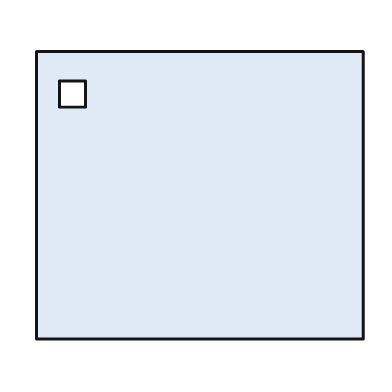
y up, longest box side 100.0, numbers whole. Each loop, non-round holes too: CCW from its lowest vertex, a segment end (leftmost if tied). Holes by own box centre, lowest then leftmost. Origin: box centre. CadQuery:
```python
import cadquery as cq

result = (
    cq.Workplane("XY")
    .moveTo(-50.0, -44.0)
    .lineTo(50.0, -44.0)
    .lineTo(50.0, 44.0)
    .lineTo(-50.0, 44.0)
    .close()
    .moveTo(-43.0, 27.0)
    .lineTo(-35.0, 27.0)
    .lineTo(-35.0, 35.0)
    .lineTo(-43.0, 35.0)
    .close()
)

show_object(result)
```